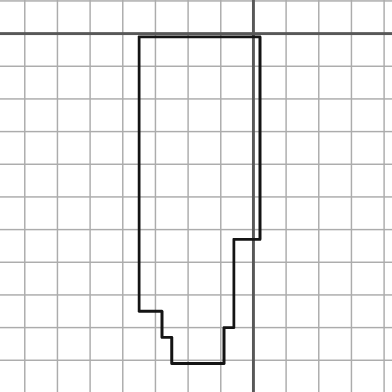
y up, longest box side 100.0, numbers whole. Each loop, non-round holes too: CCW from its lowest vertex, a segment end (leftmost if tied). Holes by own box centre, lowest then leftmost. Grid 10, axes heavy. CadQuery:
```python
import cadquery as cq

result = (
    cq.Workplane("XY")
    .moveTo(-25.0, -101.0)
    .lineTo(-9.0, -101.0)
    .lineTo(-9.0, -90.0)
    .lineTo(-6.0, -90.0)
    .lineTo(-6.0, -63.0)
    .lineTo(2.0, -63.0)
    .lineTo(2.0, -1.0)
    .lineTo(-35.0, -1.0)
    .lineTo(-35.0, -85.0)
    .lineTo(-28.0, -85.0)
    .lineTo(-28.0, -93.0)
    .lineTo(-25.0, -93.0)
    .close()
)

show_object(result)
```